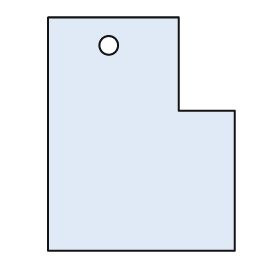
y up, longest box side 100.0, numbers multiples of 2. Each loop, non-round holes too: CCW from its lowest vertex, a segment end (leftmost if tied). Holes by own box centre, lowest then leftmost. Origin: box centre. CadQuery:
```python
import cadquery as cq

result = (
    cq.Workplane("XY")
    .moveTo(-40.0, -50.0)
    .lineTo(40.0, -50.0)
    .lineTo(40.0, 10.0)
    .lineTo(16.0, 10.0)
    .lineTo(16.0, 50.0)
    .lineTo(-40.0, 50.0)
    .close()
    .moveTo(-14.0, 38.0)
    .circle(4.0)
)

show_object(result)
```